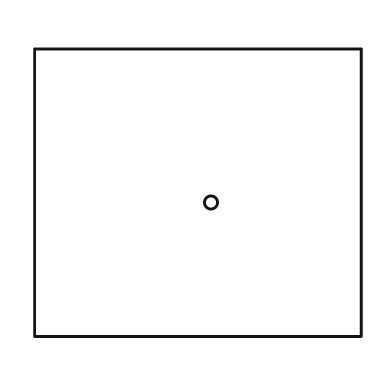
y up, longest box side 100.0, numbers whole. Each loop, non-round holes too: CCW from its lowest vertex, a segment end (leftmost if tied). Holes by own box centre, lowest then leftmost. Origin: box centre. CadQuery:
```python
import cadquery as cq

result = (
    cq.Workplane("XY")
    .moveTo(-50.0, -44.0)
    .lineTo(50.0, -44.0)
    .lineTo(50.0, 44.0)
    .lineTo(-50.0, 44.0)
    .close()
    .moveTo(4.0, -3.0)
    .circle(2.0)
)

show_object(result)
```